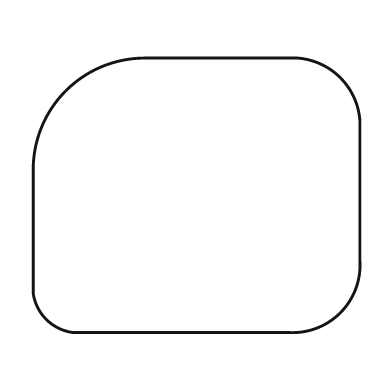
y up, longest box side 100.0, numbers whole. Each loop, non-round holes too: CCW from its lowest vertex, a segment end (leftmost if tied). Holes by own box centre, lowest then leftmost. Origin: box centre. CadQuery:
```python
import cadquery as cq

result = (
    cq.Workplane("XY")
    .moveTo(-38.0, -42.0)
    .lineTo(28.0, -42.0)
    .threePointArc((44.0, -36.0), (50.0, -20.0))
    .lineTo(50.0, 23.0)
    .threePointArc((44.0, 36.0), (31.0, 42.0))
    .lineTo(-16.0, 42.0)
    .threePointArc((-40.0, 32.0), (-50.0, 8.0))
    .lineTo(-50.0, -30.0)
    .threePointArc((-46.0, -38.0), (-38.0, -42.0))
    .close()
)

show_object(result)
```